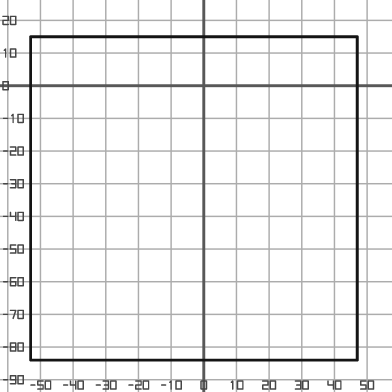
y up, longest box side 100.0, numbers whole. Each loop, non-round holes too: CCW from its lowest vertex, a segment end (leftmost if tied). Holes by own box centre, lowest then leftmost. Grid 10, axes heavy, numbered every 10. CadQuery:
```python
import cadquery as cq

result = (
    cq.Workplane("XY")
    .moveTo(-53.0, -84.0)
    .lineTo(47.0, -84.0)
    .lineTo(47.0, 15.0)
    .lineTo(-53.0, 15.0)
    .close()
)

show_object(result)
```